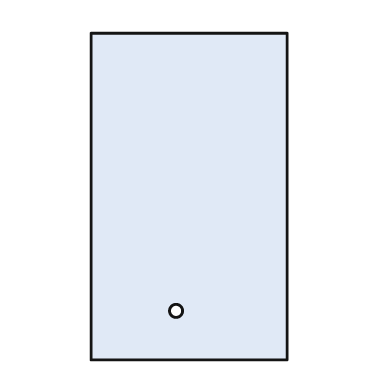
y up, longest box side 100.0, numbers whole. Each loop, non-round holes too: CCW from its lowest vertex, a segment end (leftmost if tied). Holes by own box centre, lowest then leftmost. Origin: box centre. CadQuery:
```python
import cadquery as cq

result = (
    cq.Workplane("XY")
    .moveTo(-30.0, -50.0)
    .lineTo(30.0, -50.0)
    .lineTo(30.0, 50.0)
    .lineTo(-30.0, 50.0)
    .close()
    .moveTo(-4.0, -35.0)
    .circle(2.0)
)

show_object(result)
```